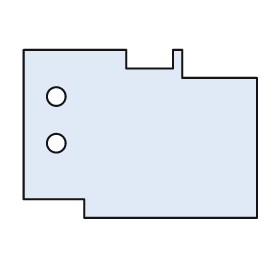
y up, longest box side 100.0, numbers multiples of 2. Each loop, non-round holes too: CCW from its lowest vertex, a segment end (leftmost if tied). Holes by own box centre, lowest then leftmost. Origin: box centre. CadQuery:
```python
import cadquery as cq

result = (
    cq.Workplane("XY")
    .moveTo(-24.0, -36.0)
    .lineTo(50.0, -36.0)
    .lineTo(50.0, 24.0)
    .lineTo(18.0, 24.0)
    .lineTo(18.0, 36.0)
    .lineTo(14.0, 36.0)
    .lineTo(14.0, 28.0)
    .lineTo(-6.0, 28.0)
    .lineTo(-6.0, 36.0)
    .lineTo(-50.0, 36.0)
    .lineTo(-50.0, -28.0)
    .lineTo(-24.0, -28.0)
    .close()
    .moveTo(-36.0, -4.0)
    .circle(4.0)
    .moveTo(-36.0, 16.0)
    .circle(4.0)
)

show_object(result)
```